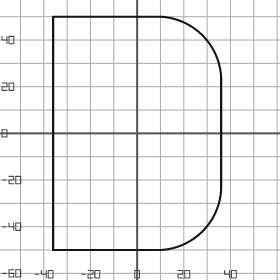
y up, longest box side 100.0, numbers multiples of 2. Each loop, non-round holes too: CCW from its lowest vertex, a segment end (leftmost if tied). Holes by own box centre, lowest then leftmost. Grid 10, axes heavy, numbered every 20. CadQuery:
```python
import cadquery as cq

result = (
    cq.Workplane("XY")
    .moveTo(-36.0, -50.0)
    .lineTo(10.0, -50.0)
    .threePointArc((28.0, -42.0), (36.0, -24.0))
    .lineTo(36.0, 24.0)
    .threePointArc((28.0, 42.0), (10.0, 50.0))
    .lineTo(-36.0, 50.0)
    .close()
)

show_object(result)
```